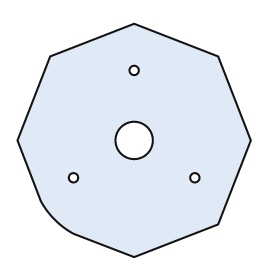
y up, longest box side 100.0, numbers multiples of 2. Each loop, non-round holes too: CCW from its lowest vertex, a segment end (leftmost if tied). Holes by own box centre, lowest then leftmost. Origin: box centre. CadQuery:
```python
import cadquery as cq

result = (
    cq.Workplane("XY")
    .moveTo(0.0, -50.0)
    .lineTo(36.0, -36.0)
    .lineTo(50.0, 0.0)
    .lineTo(36.0, 36.0)
    .lineTo(0.0, 50.0)
    .lineTo(-36.0, 36.0)
    .lineTo(-50.0, 0.0)
    .lineTo(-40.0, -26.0)
    .threePointArc((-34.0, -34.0), (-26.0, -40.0))
    .close()
    .moveTo(-26.0, -16.0)
    .circle(2.0)
    .moveTo(26.0, -16.0)
    .circle(2.0)
    .moveTo(0.0, 0.0)
    .circle(8.0)
    .moveTo(0.0, 30.0)
    .circle(2.0)
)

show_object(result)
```